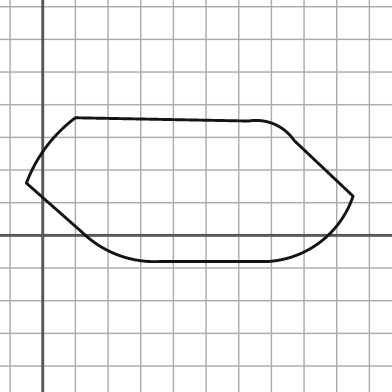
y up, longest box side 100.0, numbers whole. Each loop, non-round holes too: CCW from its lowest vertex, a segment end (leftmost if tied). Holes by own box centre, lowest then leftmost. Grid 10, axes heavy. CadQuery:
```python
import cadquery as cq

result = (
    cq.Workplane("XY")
    .moveTo(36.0, -8.0)
    .lineTo(69.0, -8.0)
    .threePointArc((85.0, -2.0), (95.0, 12.0))
    .lineTo(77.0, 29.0)
    .threePointArc((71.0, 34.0), (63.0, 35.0))
    .lineTo(10.0, 36.0)
    .threePointArc((1.0, 27.0), (-5.0, 16.0))
    .lineTo(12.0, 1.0)
    .threePointArc((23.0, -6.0), (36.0, -8.0))
    .close()
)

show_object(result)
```